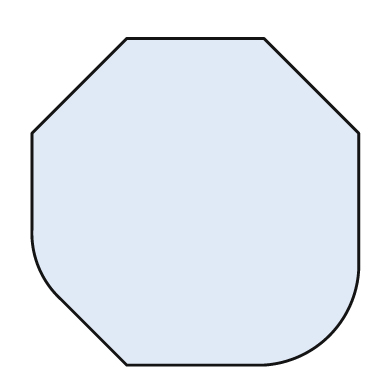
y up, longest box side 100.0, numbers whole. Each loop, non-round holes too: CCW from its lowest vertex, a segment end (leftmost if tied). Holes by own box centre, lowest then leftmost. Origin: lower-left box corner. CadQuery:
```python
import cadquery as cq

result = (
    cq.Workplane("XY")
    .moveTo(29.0, 0.0)
    .lineTo(71.0, 0.0)
    .threePointArc((91.0, 9.0), (100.0, 29.0))
    .lineTo(100.0, 71.0)
    .lineTo(71.0, 100.0)
    .lineTo(29.0, 100.0)
    .lineTo(0.0, 71.0)
    .lineTo(0.0, 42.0)
    .threePointArc((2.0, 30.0), (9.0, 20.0))
    .close()
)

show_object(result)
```